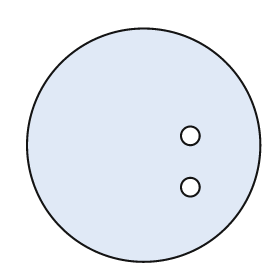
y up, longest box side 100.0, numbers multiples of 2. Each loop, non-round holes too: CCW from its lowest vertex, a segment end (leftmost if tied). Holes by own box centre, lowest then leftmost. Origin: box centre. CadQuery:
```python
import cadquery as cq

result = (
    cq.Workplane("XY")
    .moveTo(0.0, 0.0)
    .circle(50.0)
    .moveTo(20.0, -18.0)
    .circle(4.0)
    .moveTo(20.0, 4.0)
    .circle(4.0)
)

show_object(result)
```